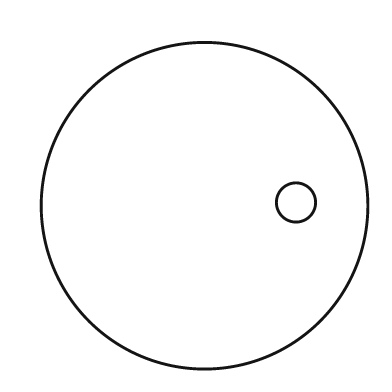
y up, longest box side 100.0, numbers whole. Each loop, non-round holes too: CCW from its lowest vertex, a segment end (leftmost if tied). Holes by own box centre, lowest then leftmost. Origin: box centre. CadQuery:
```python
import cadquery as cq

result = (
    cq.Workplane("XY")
    .moveTo(0.0, 0.0)
    .circle(50.0)
    .moveTo(28.0, 1.0)
    .circle(6.0)
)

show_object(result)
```